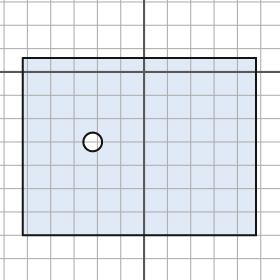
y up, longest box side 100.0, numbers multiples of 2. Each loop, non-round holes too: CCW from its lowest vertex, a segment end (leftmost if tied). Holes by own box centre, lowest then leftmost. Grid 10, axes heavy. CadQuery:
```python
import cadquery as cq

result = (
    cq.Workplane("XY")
    .moveTo(-52.0, -70.0)
    .lineTo(48.0, -70.0)
    .lineTo(48.0, 6.0)
    .lineTo(-52.0, 6.0)
    .close()
    .moveTo(-22.0, -30.0)
    .circle(4.0)
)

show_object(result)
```